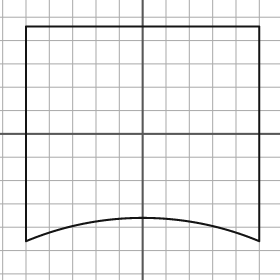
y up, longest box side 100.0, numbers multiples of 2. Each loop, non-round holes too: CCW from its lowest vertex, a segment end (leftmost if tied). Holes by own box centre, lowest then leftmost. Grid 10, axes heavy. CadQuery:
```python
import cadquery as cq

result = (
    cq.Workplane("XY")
    .moveTo(-50.0, -46.0)
    .threePointArc((0.0, -36.0), (50.0, -46.0))
    .lineTo(50.0, 46.0)
    .lineTo(-50.0, 46.0)
    .close()
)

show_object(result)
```